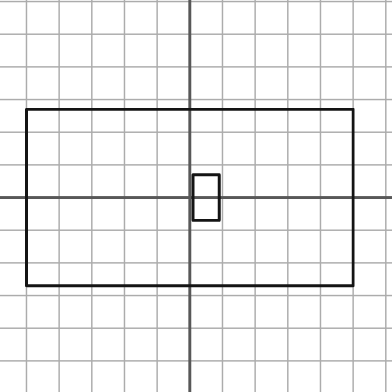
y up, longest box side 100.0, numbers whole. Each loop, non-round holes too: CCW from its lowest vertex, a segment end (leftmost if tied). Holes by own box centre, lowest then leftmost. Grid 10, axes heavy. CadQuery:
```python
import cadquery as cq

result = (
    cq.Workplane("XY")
    .moveTo(-50.0, -27.0)
    .lineTo(50.0, -27.0)
    .lineTo(50.0, 27.0)
    .lineTo(-50.0, 27.0)
    .close()
    .moveTo(1.0, -7.0)
    .lineTo(9.0, -7.0)
    .lineTo(9.0, 7.0)
    .lineTo(1.0, 7.0)
    .close()
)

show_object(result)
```